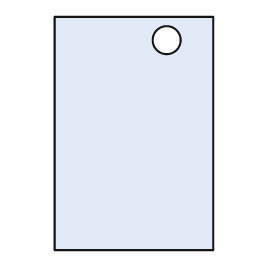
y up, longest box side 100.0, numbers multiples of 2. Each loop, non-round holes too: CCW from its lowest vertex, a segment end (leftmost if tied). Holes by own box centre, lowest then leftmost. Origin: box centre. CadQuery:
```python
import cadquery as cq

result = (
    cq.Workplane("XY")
    .moveTo(-34.0, -50.0)
    .lineTo(34.0, -50.0)
    .lineTo(34.0, 50.0)
    .lineTo(-34.0, 50.0)
    .close()
    .moveTo(14.0, 40.0)
    .circle(6.0)
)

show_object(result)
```